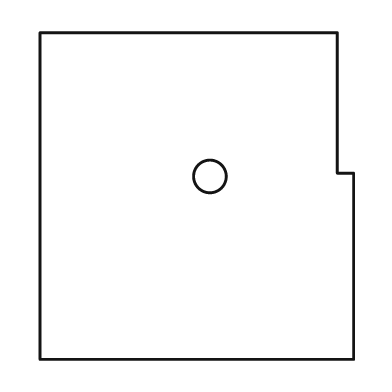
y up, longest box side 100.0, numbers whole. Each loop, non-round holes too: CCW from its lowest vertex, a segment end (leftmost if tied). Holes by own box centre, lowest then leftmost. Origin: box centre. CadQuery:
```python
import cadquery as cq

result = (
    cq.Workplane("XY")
    .moveTo(-48.0, -50.0)
    .lineTo(48.0, -50.0)
    .lineTo(48.0, 7.0)
    .lineTo(43.0, 7.0)
    .lineTo(43.0, 50.0)
    .lineTo(-48.0, 50.0)
    .close()
    .moveTo(4.0, 6.0)
    .circle(5.0)
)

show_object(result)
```